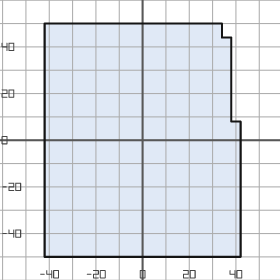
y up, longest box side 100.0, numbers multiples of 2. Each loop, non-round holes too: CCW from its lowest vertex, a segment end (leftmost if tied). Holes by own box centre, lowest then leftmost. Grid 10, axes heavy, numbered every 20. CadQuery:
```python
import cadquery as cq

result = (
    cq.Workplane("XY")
    .moveTo(-42.0, -50.0)
    .lineTo(42.0, -50.0)
    .lineTo(42.0, 8.0)
    .lineTo(38.0, 8.0)
    .lineTo(38.0, 44.0)
    .lineTo(34.0, 44.0)
    .lineTo(34.0, 50.0)
    .lineTo(-42.0, 50.0)
    .close()
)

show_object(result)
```